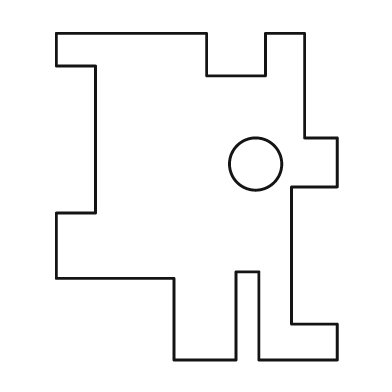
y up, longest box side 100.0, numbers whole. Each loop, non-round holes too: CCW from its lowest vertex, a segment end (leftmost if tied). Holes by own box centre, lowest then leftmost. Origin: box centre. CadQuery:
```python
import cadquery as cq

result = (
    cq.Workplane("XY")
    .moveTo(-7.0, -50.0)
    .lineTo(12.0, -50.0)
    .lineTo(12.0, -23.0)
    .lineTo(19.0, -23.0)
    .lineTo(19.0, -50.0)
    .lineTo(43.0, -50.0)
    .lineTo(43.0, -39.0)
    .lineTo(29.0, -39.0)
    .lineTo(29.0, 3.0)
    .lineTo(43.0, 3.0)
    .lineTo(43.0, 18.0)
    .lineTo(33.0, 18.0)
    .lineTo(33.0, 50.0)
    .lineTo(21.0, 50.0)
    .lineTo(21.0, 37.0)
    .lineTo(3.0, 37.0)
    .lineTo(3.0, 50.0)
    .lineTo(-43.0, 50.0)
    .lineTo(-43.0, 40.0)
    .lineTo(-31.0, 40.0)
    .lineTo(-31.0, -5.0)
    .lineTo(-43.0, -5.0)
    .lineTo(-43.0, -25.0)
    .lineTo(-7.0, -25.0)
    .close()
    .moveTo(18.0, 10.0)
    .circle(8.0)
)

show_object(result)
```